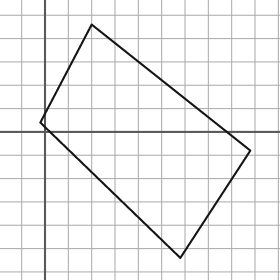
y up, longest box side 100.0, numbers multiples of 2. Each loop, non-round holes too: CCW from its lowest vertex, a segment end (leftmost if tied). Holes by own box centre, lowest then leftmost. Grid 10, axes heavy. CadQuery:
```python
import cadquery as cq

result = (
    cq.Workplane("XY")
    .moveTo(58.0, -54.0)
    .lineTo(88.0, -8.0)
    .lineTo(20.0, 46.0)
    .lineTo(-2.0, 4.0)
    .close()
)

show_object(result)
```